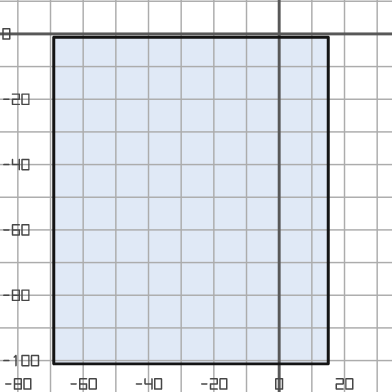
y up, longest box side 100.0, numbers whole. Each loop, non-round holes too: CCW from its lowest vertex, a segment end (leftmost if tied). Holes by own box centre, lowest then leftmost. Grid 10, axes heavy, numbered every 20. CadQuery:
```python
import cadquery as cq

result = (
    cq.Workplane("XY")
    .moveTo(-69.0, -101.0)
    .lineTo(15.0, -101.0)
    .lineTo(15.0, -1.0)
    .lineTo(-69.0, -1.0)
    .close()
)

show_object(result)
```